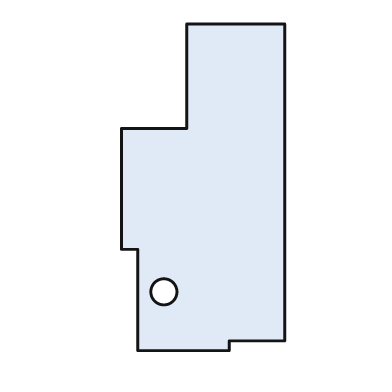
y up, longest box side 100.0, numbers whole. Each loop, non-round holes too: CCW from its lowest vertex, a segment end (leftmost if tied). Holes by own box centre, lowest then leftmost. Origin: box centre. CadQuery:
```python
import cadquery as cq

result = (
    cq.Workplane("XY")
    .moveTo(-20.0, -50.0)
    .lineTo(8.0, -50.0)
    .lineTo(8.0, -47.0)
    .lineTo(25.0, -47.0)
    .lineTo(25.0, 50.0)
    .lineTo(-5.0, 50.0)
    .lineTo(-5.0, 18.0)
    .lineTo(-25.0, 18.0)
    .lineTo(-25.0, -19.0)
    .lineTo(-20.0, -19.0)
    .close()
    .moveTo(-12.0, -32.0)
    .circle(4.0)
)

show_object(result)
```